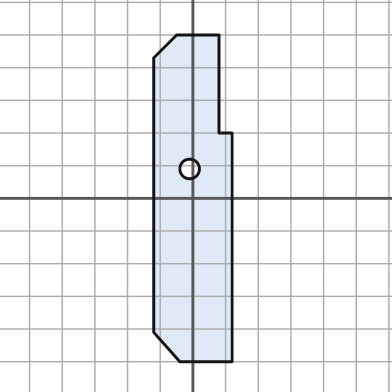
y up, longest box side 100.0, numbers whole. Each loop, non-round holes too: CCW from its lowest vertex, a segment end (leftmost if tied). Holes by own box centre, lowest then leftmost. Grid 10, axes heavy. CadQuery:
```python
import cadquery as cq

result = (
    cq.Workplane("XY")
    .moveTo(-4.0, -50.0)
    .lineTo(12.0, -50.0)
    .lineTo(12.0, 20.0)
    .lineTo(8.0, 20.0)
    .lineTo(8.0, 50.0)
    .lineTo(-5.0, 50.0)
    .lineTo(-12.0, 43.0)
    .lineTo(-12.0, -41.0)
    .close()
    .moveTo(-1.0, 9.0)
    .circle(3.0)
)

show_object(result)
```